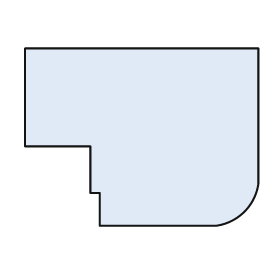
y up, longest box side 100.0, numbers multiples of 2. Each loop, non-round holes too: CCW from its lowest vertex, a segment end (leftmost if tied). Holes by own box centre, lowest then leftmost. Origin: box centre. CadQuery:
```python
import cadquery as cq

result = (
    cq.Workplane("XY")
    .moveTo(-18.0, -38.0)
    .lineTo(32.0, -38.0)
    .threePointArc((44.0, -32.0), (50.0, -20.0))
    .lineTo(50.0, 38.0)
    .lineTo(-50.0, 38.0)
    .lineTo(-50.0, -4.0)
    .lineTo(-22.0, -4.0)
    .lineTo(-22.0, -24.0)
    .lineTo(-18.0, -24.0)
    .close()
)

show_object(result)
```